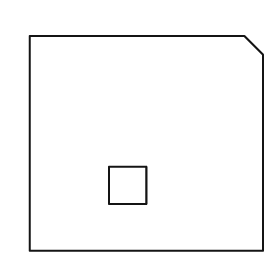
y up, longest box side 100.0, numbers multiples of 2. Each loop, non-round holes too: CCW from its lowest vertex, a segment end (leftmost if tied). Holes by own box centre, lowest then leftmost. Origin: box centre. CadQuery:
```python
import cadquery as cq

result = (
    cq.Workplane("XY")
    .moveTo(-50.0, -46.0)
    .lineTo(50.0, -46.0)
    .lineTo(50.0, 38.0)
    .lineTo(42.0, 46.0)
    .lineTo(-50.0, 46.0)
    .close()
    .moveTo(-16.0, -26.0)
    .lineTo(0.0, -26.0)
    .lineTo(0.0, -10.0)
    .lineTo(-16.0, -10.0)
    .close()
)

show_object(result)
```